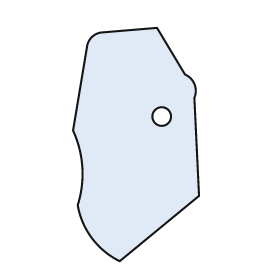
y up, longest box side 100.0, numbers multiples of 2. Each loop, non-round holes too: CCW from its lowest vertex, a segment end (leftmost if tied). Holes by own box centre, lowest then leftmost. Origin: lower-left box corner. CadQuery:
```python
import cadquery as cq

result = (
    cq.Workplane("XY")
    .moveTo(20.0, 0.0)
    .lineTo(54.0, 28.0)
    .lineTo(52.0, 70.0)
    .threePointArc((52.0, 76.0), (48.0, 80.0))
    .lineTo(36.0, 100.0)
    .lineTo(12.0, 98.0)
    .threePointArc((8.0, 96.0), (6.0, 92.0))
    .lineTo(0.0, 56.0)
    .threePointArc((4.0, 40.0), (2.0, 24.0))
    .threePointArc((8.0, 10.0), (20.0, 0.0))
    .close()
    .moveTo(38.0, 62.0)
    .circle(4.0)
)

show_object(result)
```